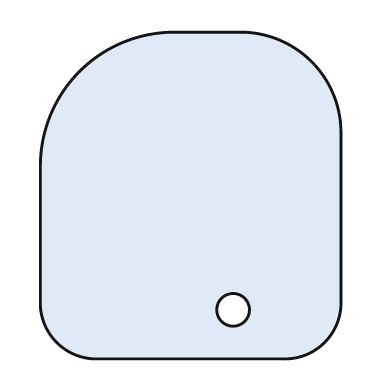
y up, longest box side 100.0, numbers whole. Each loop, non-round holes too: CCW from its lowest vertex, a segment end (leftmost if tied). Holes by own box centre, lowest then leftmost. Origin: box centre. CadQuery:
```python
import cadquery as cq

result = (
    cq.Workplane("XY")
    .moveTo(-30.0, -50.0)
    .lineTo(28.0, -50.0)
    .threePointArc((41.0, -45.0), (46.0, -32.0))
    .lineTo(46.0, 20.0)
    .threePointArc((37.0, 41.0), (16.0, 50.0))
    .lineTo(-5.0, 50.0)
    .threePointArc((-34.0, 38.0), (-46.0, 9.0))
    .lineTo(-46.0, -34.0)
    .threePointArc((-41.0, -45.0), (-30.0, -50.0))
    .close()
    .moveTo(13.0, -35.0)
    .circle(5.0)
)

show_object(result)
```